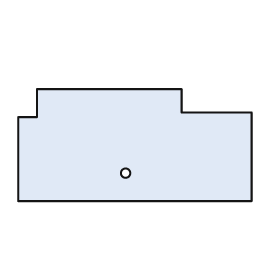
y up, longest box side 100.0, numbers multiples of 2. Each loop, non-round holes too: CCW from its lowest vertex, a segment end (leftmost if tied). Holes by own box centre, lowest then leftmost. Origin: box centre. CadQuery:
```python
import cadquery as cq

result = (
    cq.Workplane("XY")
    .moveTo(-50.0, -24.0)
    .lineTo(50.0, -24.0)
    .lineTo(50.0, 14.0)
    .lineTo(20.0, 14.0)
    .lineTo(20.0, 24.0)
    .lineTo(-42.0, 24.0)
    .lineTo(-42.0, 12.0)
    .lineTo(-50.0, 12.0)
    .close()
    .moveTo(-4.0, -12.0)
    .circle(2.0)
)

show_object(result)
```